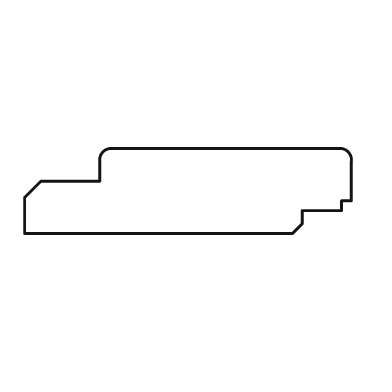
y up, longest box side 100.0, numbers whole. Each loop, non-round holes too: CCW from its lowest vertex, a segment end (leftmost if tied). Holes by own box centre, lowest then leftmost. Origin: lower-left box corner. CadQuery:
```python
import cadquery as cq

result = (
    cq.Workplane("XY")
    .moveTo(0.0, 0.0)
    .lineTo(82.0, 0.0)
    .lineTo(85.0, 3.0)
    .lineTo(85.0, 7.0)
    .lineTo(97.0, 7.0)
    .lineTo(97.0, 10.0)
    .lineTo(100.0, 10.0)
    .lineTo(100.0, 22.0)
    .threePointArc((99.0, 25.0), (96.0, 26.0))
    .lineTo(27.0, 26.0)
    .threePointArc((24.0, 25.0), (23.0, 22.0))
    .lineTo(23.0, 16.0)
    .lineTo(5.0, 16.0)
    .lineTo(0.0, 11.0)
    .close()
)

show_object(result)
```